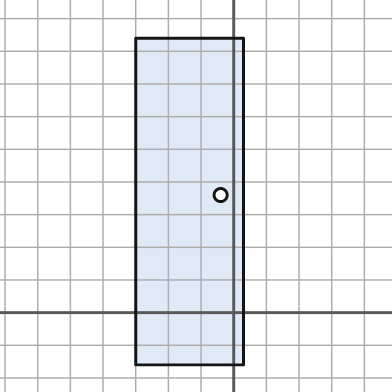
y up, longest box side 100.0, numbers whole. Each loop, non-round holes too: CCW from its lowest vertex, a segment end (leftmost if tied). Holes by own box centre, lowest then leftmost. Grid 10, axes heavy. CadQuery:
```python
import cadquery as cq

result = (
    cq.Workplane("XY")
    .moveTo(-30.0, -16.0)
    .lineTo(3.0, -16.0)
    .lineTo(3.0, 84.0)
    .lineTo(-30.0, 84.0)
    .close()
    .moveTo(-4.0, 36.0)
    .circle(2.0)
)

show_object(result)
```